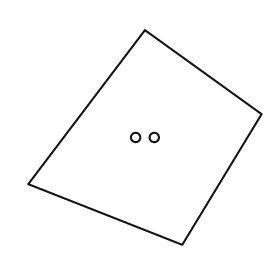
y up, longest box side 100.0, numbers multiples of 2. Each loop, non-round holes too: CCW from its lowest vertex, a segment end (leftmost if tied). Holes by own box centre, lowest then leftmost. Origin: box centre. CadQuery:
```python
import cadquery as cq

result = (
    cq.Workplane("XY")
    .moveTo(16.0, -46.0)
    .lineTo(50.0, 10.0)
    .lineTo(0.0, 46.0)
    .lineTo(-50.0, -20.0)
    .close()
    .moveTo(-4.0, 0.0)
    .circle(2.0)
    .moveTo(4.0, 0.0)
    .circle(2.0)
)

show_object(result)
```